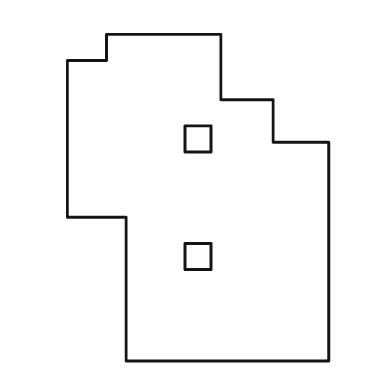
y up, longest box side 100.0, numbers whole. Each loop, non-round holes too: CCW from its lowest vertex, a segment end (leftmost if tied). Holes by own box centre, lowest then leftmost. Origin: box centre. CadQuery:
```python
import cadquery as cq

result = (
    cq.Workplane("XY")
    .moveTo(-22.0, -50.0)
    .lineTo(40.0, -50.0)
    .lineTo(40.0, 17.0)
    .lineTo(23.0, 17.0)
    .lineTo(23.0, 30.0)
    .lineTo(7.0, 30.0)
    .lineTo(7.0, 50.0)
    .lineTo(-28.0, 50.0)
    .lineTo(-28.0, 42.0)
    .lineTo(-40.0, 42.0)
    .lineTo(-40.0, -6.0)
    .lineTo(-22.0, -6.0)
    .close()
    .moveTo(-4.0, -22.0)
    .lineTo(4.0, -22.0)
    .lineTo(4.0, -14.0)
    .lineTo(-4.0, -14.0)
    .close()
    .moveTo(-4.0, 14.0)
    .lineTo(4.0, 14.0)
    .lineTo(4.0, 22.0)
    .lineTo(-4.0, 22.0)
    .close()
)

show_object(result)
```